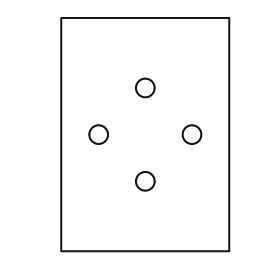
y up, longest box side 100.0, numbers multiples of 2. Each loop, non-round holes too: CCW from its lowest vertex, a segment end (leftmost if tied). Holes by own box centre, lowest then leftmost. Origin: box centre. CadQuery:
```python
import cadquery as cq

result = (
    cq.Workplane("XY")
    .moveTo(-36.0, -50.0)
    .lineTo(36.0, -50.0)
    .lineTo(36.0, 50.0)
    .lineTo(-36.0, 50.0)
    .close()
    .moveTo(0.0, -20.0)
    .circle(4.0)
    .moveTo(-20.0, 0.0)
    .circle(4.0)
    .moveTo(20.0, 0.0)
    .circle(4.0)
    .moveTo(0.0, 20.0)
    .circle(4.0)
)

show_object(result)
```